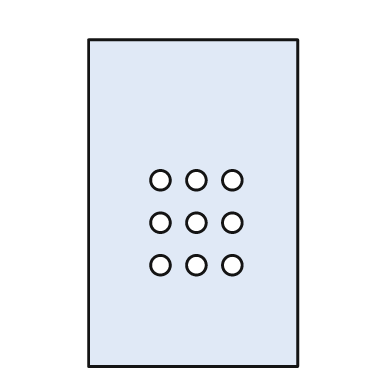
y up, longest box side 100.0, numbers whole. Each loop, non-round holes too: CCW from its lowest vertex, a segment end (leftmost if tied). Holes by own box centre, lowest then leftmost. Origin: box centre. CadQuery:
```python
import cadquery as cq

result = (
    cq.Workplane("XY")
    .moveTo(-32.0, -50.0)
    .lineTo(32.0, -50.0)
    .lineTo(32.0, 50.0)
    .lineTo(-32.0, 50.0)
    .close()
    .moveTo(-10.0, -19.0)
    .circle(3.0)
    .moveTo(1.0, -19.0)
    .circle(3.0)
    .moveTo(12.0, -19.0)
    .circle(3.0)
    .moveTo(-10.0, -6.0)
    .circle(3.0)
    .moveTo(1.0, -6.0)
    .circle(3.0)
    .moveTo(12.0, -6.0)
    .circle(3.0)
    .moveTo(-10.0, 7.0)
    .circle(3.0)
    .moveTo(1.0, 7.0)
    .circle(3.0)
    .moveTo(12.0, 7.0)
    .circle(3.0)
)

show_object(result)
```